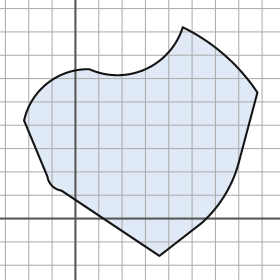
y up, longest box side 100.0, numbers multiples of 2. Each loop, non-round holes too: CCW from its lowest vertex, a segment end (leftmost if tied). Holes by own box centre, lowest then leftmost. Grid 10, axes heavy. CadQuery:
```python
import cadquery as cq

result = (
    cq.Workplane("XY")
    .moveTo(36.0, -16.0)
    .lineTo(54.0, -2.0)
    .threePointArc((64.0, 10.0), (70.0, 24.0))
    .lineTo(78.0, 54.0)
    .threePointArc((64.0, 70.0), (46.0, 82.0))
    .threePointArc((30.0, 64.0), (6.0, 64.0))
    .threePointArc((-12.0, 58.0), (-22.0, 42.0))
    .lineTo(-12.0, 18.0)
    .threePointArc((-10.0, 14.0), (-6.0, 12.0))
    .close()
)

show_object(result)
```